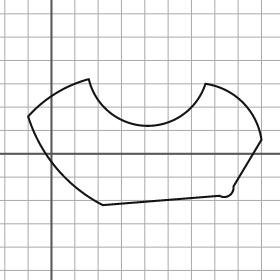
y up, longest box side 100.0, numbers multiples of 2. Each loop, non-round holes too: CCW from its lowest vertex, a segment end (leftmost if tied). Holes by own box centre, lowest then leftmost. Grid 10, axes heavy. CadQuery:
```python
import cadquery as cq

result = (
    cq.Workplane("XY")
    .moveTo(22.0, -22.0)
    .lineTo(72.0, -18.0)
    .threePointArc((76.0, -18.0), (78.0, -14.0))
    .lineTo(90.0, 6.0)
    .threePointArc((82.0, 22.0), (66.0, 30.0))
    .threePointArc((40.0, 12.0), (16.0, 32.0))
    .threePointArc((2.0, 26.0), (-10.0, 16.0))
    .threePointArc((2.0, -6.0), (22.0, -22.0))
    .close()
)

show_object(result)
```